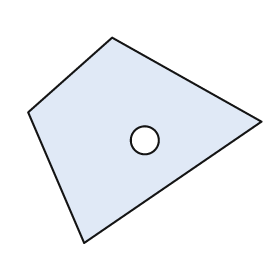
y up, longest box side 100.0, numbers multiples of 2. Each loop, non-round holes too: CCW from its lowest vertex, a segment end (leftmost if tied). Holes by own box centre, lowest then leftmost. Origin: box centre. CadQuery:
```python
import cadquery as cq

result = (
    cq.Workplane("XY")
    .moveTo(-26.0, -44.0)
    .lineTo(50.0, 8.0)
    .lineTo(-14.0, 44.0)
    .lineTo(-50.0, 12.0)
    .close()
    .moveTo(0.0, 0.0)
    .circle(6.0)
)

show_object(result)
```